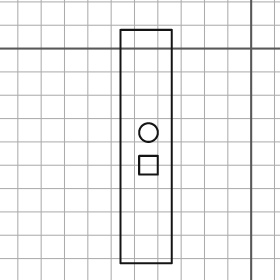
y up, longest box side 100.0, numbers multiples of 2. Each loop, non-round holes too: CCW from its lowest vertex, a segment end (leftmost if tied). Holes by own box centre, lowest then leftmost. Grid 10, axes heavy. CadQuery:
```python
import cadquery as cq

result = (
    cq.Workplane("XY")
    .moveTo(-56.0, -92.0)
    .lineTo(-34.0, -92.0)
    .lineTo(-34.0, 8.0)
    .lineTo(-56.0, 8.0)
    .close()
    .moveTo(-48.0, -54.0)
    .lineTo(-40.0, -54.0)
    .lineTo(-40.0, -46.0)
    .lineTo(-48.0, -46.0)
    .close()
    .moveTo(-44.0, -36.0)
    .circle(4.0)
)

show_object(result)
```